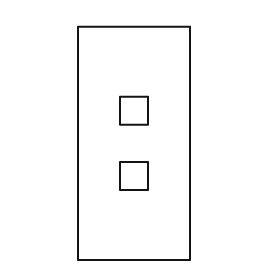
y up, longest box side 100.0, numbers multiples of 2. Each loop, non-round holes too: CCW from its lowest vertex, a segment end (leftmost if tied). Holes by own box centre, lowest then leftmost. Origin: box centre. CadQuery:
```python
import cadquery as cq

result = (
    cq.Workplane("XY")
    .moveTo(-24.0, -50.0)
    .lineTo(24.0, -50.0)
    .lineTo(24.0, 50.0)
    .lineTo(-24.0, 50.0)
    .close()
    .moveTo(-6.0, -20.0)
    .lineTo(6.0, -20.0)
    .lineTo(6.0, -8.0)
    .lineTo(-6.0, -8.0)
    .close()
    .moveTo(-6.0, 8.0)
    .lineTo(6.0, 8.0)
    .lineTo(6.0, 20.0)
    .lineTo(-6.0, 20.0)
    .close()
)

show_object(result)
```